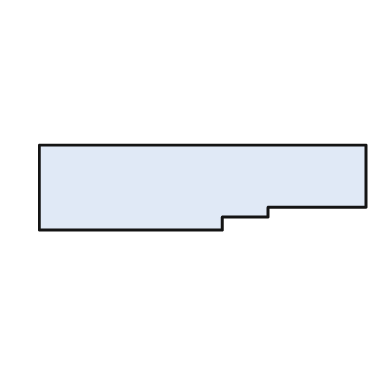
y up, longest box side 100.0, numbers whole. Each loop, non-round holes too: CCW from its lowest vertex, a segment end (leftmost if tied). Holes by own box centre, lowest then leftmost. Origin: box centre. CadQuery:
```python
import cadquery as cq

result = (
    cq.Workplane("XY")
    .moveTo(-50.0, -13.0)
    .lineTo(6.0, -13.0)
    .lineTo(6.0, -9.0)
    .lineTo(20.0, -9.0)
    .lineTo(20.0, -6.0)
    .lineTo(50.0, -6.0)
    .lineTo(50.0, 13.0)
    .lineTo(-50.0, 13.0)
    .close()
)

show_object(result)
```